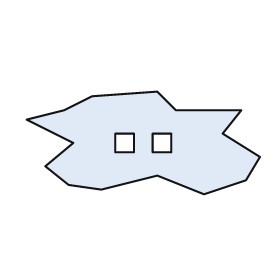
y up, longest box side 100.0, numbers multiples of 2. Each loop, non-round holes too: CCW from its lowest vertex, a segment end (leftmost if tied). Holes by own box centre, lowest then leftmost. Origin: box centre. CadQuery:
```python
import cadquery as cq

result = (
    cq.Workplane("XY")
    .moveTo(26.0, -22.0)
    .lineTo(44.0, -16.0)
    .lineTo(50.0, -6.0)
    .lineTo(34.0, 4.0)
    .lineTo(42.0, 14.0)
    .lineTo(14.0, 14.0)
    .lineTo(6.0, 22.0)
    .lineTo(-22.0, 20.0)
    .lineTo(-34.0, 14.0)
    .lineTo(-50.0, 10.0)
    .lineTo(-30.0, 0.0)
    .lineTo(-42.0, -10.0)
    .lineTo(-32.0, -18.0)
    .lineTo(-18.0, -20.0)
    .lineTo(6.0, -14.0)
    .close()
    .moveTo(-12.0, -4.0)
    .lineTo(-4.0, -4.0)
    .lineTo(-4.0, 4.0)
    .lineTo(-12.0, 4.0)
    .close()
    .moveTo(4.0, -4.0)
    .lineTo(12.0, -4.0)
    .lineTo(12.0, 4.0)
    .lineTo(4.0, 4.0)
    .close()
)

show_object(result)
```